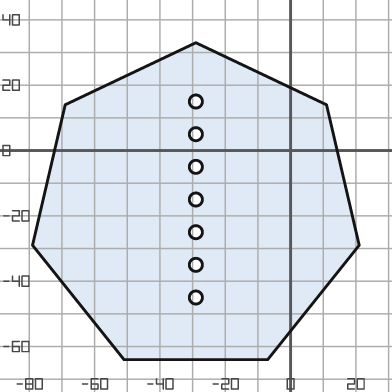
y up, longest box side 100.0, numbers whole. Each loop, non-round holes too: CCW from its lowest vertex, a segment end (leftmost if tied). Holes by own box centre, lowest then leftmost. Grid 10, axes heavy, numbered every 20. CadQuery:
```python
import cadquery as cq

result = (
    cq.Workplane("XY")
    .moveTo(-51.0, -64.0)
    .lineTo(-7.0, -64.0)
    .lineTo(21.0, -29.0)
    .lineTo(11.0, 14.0)
    .lineTo(-29.0, 33.0)
    .lineTo(-69.0, 14.0)
    .lineTo(-79.0, -29.0)
    .close()
    .moveTo(-29.0, -45.0)
    .circle(2.0)
    .moveTo(-29.0, -35.0)
    .circle(2.0)
    .moveTo(-29.0, -25.0)
    .circle(2.0)
    .moveTo(-29.0, -15.0)
    .circle(2.0)
    .moveTo(-29.0, -5.0)
    .circle(2.0)
    .moveTo(-29.0, 5.0)
    .circle(2.0)
    .moveTo(-29.0, 15.0)
    .circle(2.0)
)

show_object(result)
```